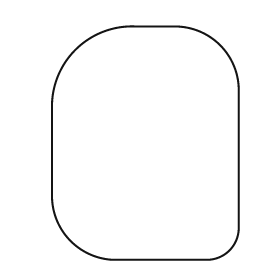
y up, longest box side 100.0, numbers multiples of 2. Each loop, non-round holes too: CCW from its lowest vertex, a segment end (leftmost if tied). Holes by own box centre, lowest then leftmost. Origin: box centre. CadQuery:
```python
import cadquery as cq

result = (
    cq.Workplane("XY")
    .moveTo(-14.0, -50.0)
    .lineTo(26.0, -50.0)
    .threePointArc((36.0, -46.0), (40.0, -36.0))
    .lineTo(40.0, 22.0)
    .threePointArc((32.0, 42.0), (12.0, 50.0))
    .lineTo(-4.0, 50.0)
    .threePointArc((-30.0, 40.0), (-40.0, 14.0))
    .lineTo(-40.0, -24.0)
    .threePointArc((-32.0, -42.0), (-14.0, -50.0))
    .close()
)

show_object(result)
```